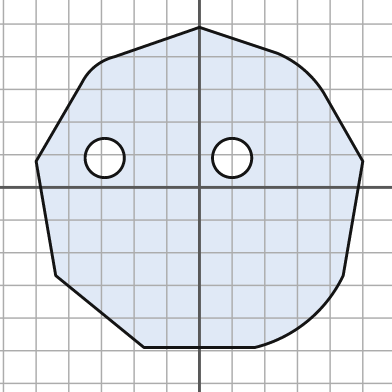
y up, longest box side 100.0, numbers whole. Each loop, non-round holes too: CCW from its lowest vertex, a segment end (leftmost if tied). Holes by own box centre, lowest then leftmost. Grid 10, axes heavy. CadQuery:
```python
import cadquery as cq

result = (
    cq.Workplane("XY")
    .moveTo(-17.0, -49.0)
    .lineTo(17.0, -49.0)
    .threePointArc((33.0, -41.0), (44.0, -27.0))
    .lineTo(50.0, 8.0)
    .lineTo(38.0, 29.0)
    .threePointArc((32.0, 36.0), (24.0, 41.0))
    .lineTo(0.0, 49.0)
    .lineTo(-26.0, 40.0)
    .threePointArc((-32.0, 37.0), (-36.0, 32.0))
    .lineTo(-50.0, 8.0)
    .lineTo(-44.0, -27.0)
    .close()
    .moveTo(-29.0, 9.0)
    .circle(6.0)
    .moveTo(10.0, 9.0)
    .circle(6.0)
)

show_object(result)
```